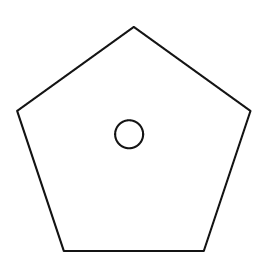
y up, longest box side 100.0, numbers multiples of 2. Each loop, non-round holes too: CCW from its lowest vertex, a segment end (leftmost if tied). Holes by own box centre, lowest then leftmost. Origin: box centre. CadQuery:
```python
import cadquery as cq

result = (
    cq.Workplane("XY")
    .moveTo(-30.0, -48.0)
    .lineTo(30.0, -48.0)
    .lineTo(50.0, 12.0)
    .lineTo(0.0, 48.0)
    .lineTo(-50.0, 12.0)
    .close()
    .moveTo(-2.0, 2.0)
    .circle(6.0)
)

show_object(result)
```